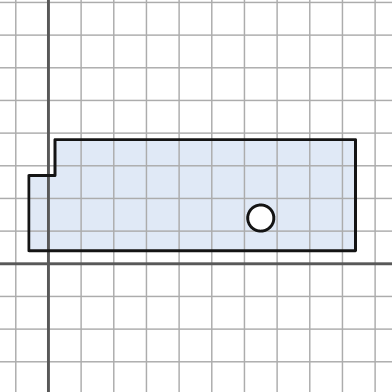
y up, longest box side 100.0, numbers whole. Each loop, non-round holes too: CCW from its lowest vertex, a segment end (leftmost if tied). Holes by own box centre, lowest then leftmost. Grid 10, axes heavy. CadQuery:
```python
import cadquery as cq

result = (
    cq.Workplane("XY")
    .moveTo(-6.0, 4.0)
    .lineTo(94.0, 4.0)
    .lineTo(94.0, 38.0)
    .lineTo(2.0, 38.0)
    .lineTo(2.0, 27.0)
    .lineTo(-6.0, 27.0)
    .close()
    .moveTo(65.0, 14.0)
    .circle(4.0)
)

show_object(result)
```